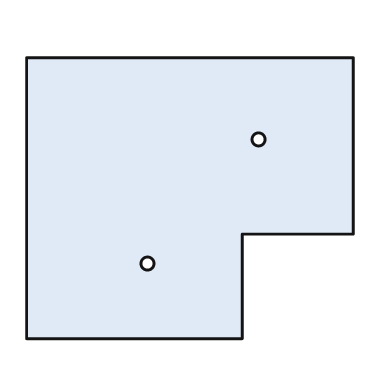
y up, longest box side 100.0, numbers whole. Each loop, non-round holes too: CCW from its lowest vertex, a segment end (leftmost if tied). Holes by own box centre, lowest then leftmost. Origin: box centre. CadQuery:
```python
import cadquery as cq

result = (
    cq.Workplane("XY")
    .moveTo(-50.0, -43.0)
    .lineTo(16.0, -43.0)
    .lineTo(16.0, -11.0)
    .lineTo(50.0, -11.0)
    .lineTo(50.0, 43.0)
    .lineTo(-50.0, 43.0)
    .close()
    .moveTo(-13.0, -20.0)
    .circle(2.0)
    .moveTo(21.0, 18.0)
    .circle(2.0)
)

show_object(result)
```